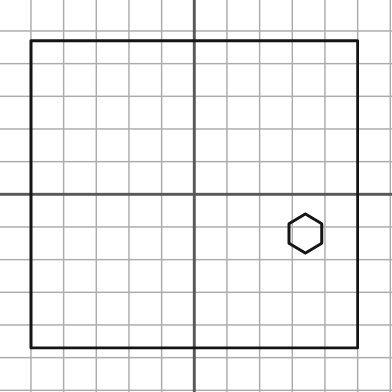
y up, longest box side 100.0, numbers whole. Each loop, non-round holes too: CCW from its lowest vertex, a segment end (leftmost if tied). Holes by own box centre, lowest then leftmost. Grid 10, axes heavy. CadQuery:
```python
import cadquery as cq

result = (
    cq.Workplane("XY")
    .moveTo(-50.0, -47.0)
    .lineTo(50.0, -47.0)
    .lineTo(50.0, 47.0)
    .lineTo(-50.0, 47.0)
    .close()
    .moveTo(34.0, -18.0)
    .lineTo(39.0, -15.0)
    .lineTo(39.0, -9.0)
    .lineTo(34.0, -6.0)
    .lineTo(29.0, -9.0)
    .lineTo(29.0, -15.0)
    .close()
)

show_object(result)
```